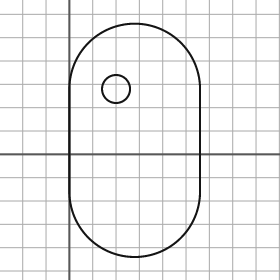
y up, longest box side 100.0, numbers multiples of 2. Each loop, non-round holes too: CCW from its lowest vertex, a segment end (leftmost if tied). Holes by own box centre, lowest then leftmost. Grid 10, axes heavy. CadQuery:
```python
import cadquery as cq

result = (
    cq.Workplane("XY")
    .moveTo(0.0, -16.0)
    .threePointArc((28.0, -44.0), (56.0, -16.0))
    .lineTo(56.0, 28.0)
    .threePointArc((28.0, 56.0), (0.0, 28.0))
    .close()
    .moveTo(20.0, 28.0)
    .circle(6.0)
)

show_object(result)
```